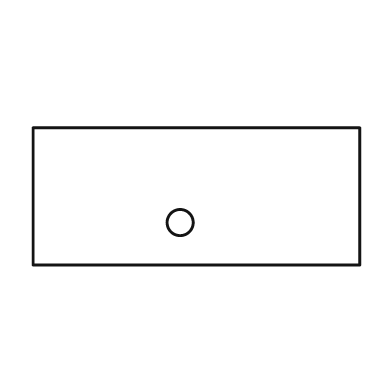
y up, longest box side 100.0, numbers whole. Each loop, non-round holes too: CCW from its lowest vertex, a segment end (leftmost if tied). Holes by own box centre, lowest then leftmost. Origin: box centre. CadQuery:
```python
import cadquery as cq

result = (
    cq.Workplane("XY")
    .moveTo(-50.0, -21.0)
    .lineTo(50.0, -21.0)
    .lineTo(50.0, 21.0)
    .lineTo(-50.0, 21.0)
    .close()
    .moveTo(-5.0, -8.0)
    .circle(4.0)
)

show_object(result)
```